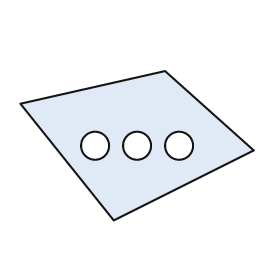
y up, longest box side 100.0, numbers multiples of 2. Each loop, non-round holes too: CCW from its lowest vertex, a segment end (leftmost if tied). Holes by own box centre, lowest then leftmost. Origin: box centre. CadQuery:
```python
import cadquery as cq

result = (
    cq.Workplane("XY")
    .moveTo(-10.0, -32.0)
    .lineTo(50.0, -2.0)
    .lineTo(12.0, 32.0)
    .lineTo(-50.0, 18.0)
    .close()
    .moveTo(-18.0, 0.0)
    .circle(6.0)
    .moveTo(0.0, 0.0)
    .circle(6.0)
    .moveTo(18.0, 0.0)
    .circle(6.0)
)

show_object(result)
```